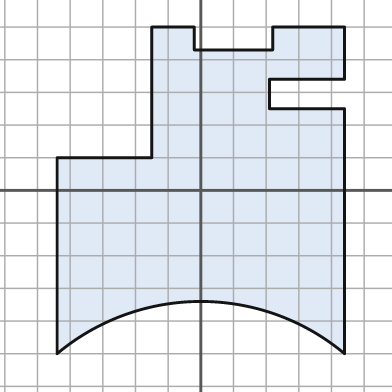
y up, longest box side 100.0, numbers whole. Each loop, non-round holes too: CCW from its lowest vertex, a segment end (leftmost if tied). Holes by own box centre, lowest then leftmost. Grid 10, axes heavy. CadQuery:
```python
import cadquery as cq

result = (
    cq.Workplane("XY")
    .moveTo(-44.0, -50.0)
    .threePointArc((0.0, -34.0), (44.0, -50.0))
    .lineTo(44.0, 25.0)
    .lineTo(21.0, 25.0)
    .lineTo(21.0, 34.0)
    .lineTo(44.0, 34.0)
    .lineTo(44.0, 50.0)
    .lineTo(22.0, 50.0)
    .lineTo(22.0, 43.0)
    .lineTo(-2.0, 43.0)
    .lineTo(-2.0, 50.0)
    .lineTo(-15.0, 50.0)
    .lineTo(-15.0, 10.0)
    .lineTo(-44.0, 10.0)
    .close()
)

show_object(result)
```